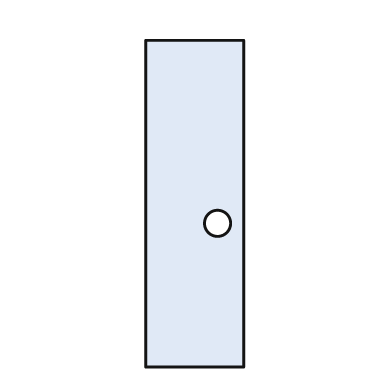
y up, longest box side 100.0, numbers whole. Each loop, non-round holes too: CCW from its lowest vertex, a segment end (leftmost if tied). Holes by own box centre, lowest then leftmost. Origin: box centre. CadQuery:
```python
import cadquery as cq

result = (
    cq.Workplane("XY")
    .moveTo(-15.0, -50.0)
    .lineTo(15.0, -50.0)
    .lineTo(15.0, 50.0)
    .lineTo(-15.0, 50.0)
    .close()
    .moveTo(7.0, -6.0)
    .circle(4.0)
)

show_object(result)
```